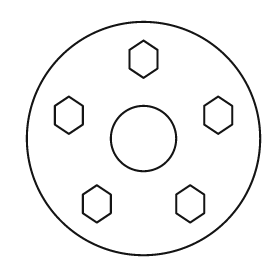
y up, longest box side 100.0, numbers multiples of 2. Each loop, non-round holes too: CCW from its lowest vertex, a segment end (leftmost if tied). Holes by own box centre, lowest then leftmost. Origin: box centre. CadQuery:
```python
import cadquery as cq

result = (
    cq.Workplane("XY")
    .moveTo(0.0, 0.0)
    .circle(50.0)
    .moveTo(-20.0, -36.0)
    .lineTo(-14.0, -32.0)
    .lineTo(-14.0, -24.0)
    .lineTo(-20.0, -20.0)
    .lineTo(-26.0, -24.0)
    .lineTo(-26.0, -32.0)
    .close()
    .moveTo(20.0, -36.0)
    .lineTo(26.0, -32.0)
    .lineTo(26.0, -24.0)
    .lineTo(20.0, -20.0)
    .lineTo(14.0, -24.0)
    .lineTo(14.0, -32.0)
    .close()
    .moveTo(0.0, 0.0)
    .circle(14.0)
    .moveTo(-32.0, 2.0)
    .lineTo(-26.0, 6.0)
    .lineTo(-26.0, 14.0)
    .lineTo(-32.0, 18.0)
    .lineTo(-38.0, 14.0)
    .lineTo(-38.0, 6.0)
    .close()
    .moveTo(32.0, 2.0)
    .lineTo(38.0, 6.0)
    .lineTo(38.0, 14.0)
    .lineTo(32.0, 18.0)
    .lineTo(26.0, 14.0)
    .lineTo(26.0, 6.0)
    .close()
    .moveTo(0.0, 26.0)
    .lineTo(6.0, 30.0)
    .lineTo(6.0, 38.0)
    .lineTo(0.0, 42.0)
    .lineTo(-6.0, 38.0)
    .lineTo(-6.0, 30.0)
    .close()
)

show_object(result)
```